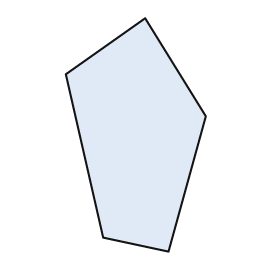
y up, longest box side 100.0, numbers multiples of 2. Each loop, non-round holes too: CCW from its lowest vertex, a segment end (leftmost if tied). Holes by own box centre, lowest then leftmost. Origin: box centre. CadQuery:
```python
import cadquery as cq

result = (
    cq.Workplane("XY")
    .moveTo(14.0, -50.0)
    .lineTo(30.0, 8.0)
    .lineTo(4.0, 50.0)
    .lineTo(-30.0, 26.0)
    .lineTo(-14.0, -44.0)
    .close()
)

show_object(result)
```